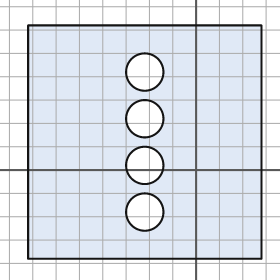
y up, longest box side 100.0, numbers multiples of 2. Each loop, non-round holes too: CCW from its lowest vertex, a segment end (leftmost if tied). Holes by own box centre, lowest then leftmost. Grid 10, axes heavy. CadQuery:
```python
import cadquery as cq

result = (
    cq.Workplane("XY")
    .moveTo(-72.0, -38.0)
    .lineTo(28.0, -38.0)
    .lineTo(28.0, 62.0)
    .lineTo(-72.0, 62.0)
    .close()
    .moveTo(-22.0, -18.0)
    .circle(8.0)
    .moveTo(-22.0, 2.0)
    .circle(8.0)
    .moveTo(-22.0, 22.0)
    .circle(8.0)
    .moveTo(-22.0, 42.0)
    .circle(8.0)
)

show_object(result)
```